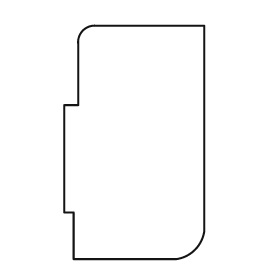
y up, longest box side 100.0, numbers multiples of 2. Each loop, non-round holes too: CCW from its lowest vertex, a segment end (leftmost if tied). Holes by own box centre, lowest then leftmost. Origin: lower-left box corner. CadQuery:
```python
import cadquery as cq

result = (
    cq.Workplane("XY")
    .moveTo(4.0, 0.0)
    .lineTo(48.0, 0.0)
    .threePointArc((56.0, 4.0), (60.0, 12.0))
    .lineTo(60.0, 100.0)
    .lineTo(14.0, 100.0)
    .threePointArc((8.0, 98.0), (6.0, 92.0))
    .lineTo(6.0, 66.0)
    .lineTo(0.0, 66.0)
    .lineTo(0.0, 20.0)
    .lineTo(4.0, 20.0)
    .close()
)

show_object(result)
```